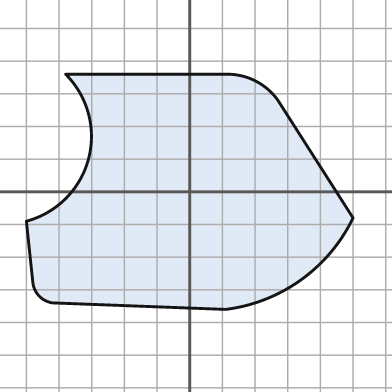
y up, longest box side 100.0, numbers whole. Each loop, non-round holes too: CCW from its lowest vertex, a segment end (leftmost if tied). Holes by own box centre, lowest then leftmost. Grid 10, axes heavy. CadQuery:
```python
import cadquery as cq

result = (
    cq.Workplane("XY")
    .moveTo(11.0, -36.0)
    .threePointArc((34.0, -27.0), (50.0, -8.0))
    .lineTo(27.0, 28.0)
    .threePointArc((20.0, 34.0), (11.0, 36.0))
    .lineTo(-38.0, 36.0)
    .threePointArc((-31.0, 10.0), (-50.0, -9.0))
    .lineTo(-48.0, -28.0)
    .threePointArc((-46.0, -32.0), (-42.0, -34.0))
    .close()
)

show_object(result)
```